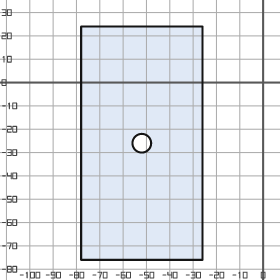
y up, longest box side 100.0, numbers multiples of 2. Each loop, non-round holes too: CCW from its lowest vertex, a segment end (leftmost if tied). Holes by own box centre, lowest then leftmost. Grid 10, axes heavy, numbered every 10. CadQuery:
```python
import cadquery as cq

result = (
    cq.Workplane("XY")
    .moveTo(-78.0, -76.0)
    .lineTo(-26.0, -76.0)
    .lineTo(-26.0, 24.0)
    .lineTo(-78.0, 24.0)
    .close()
    .moveTo(-52.0, -26.0)
    .circle(4.0)
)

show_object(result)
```